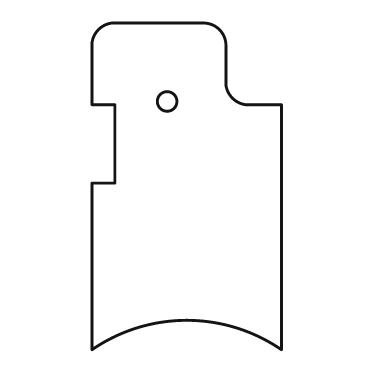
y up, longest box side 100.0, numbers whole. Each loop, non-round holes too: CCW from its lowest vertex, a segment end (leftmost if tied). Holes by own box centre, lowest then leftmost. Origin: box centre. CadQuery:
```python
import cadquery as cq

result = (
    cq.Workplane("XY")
    .moveTo(-29.0, -50.0)
    .threePointArc((0.0, -41.0), (29.0, -50.0))
    .lineTo(29.0, 25.0)
    .lineTo(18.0, 25.0)
    .threePointArc((14.0, 27.0), (12.0, 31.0))
    .lineTo(12.0, 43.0)
    .threePointArc((10.0, 48.0), (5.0, 50.0))
    .lineTo(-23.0, 50.0)
    .threePointArc((-27.0, 48.0), (-29.0, 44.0))
    .lineTo(-29.0, 25.0)
    .lineTo(-22.0, 25.0)
    .lineTo(-22.0, 1.0)
    .lineTo(-29.0, 1.0)
    .close()
    .moveTo(-6.0, 26.0)
    .circle(3.0)
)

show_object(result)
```